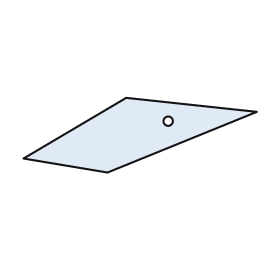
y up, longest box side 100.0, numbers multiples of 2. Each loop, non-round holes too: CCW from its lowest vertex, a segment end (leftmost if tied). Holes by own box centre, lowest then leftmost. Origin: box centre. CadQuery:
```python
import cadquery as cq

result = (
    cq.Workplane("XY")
    .moveTo(-14.0, -16.0)
    .lineTo(50.0, 10.0)
    .lineTo(-6.0, 16.0)
    .lineTo(-50.0, -10.0)
    .close()
    .moveTo(12.0, 6.0)
    .circle(2.0)
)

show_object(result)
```